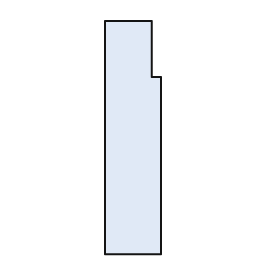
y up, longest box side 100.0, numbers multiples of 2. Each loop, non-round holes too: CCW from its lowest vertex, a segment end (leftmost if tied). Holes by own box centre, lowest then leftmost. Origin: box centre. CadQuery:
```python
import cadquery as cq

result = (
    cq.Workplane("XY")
    .moveTo(-12.0, -50.0)
    .lineTo(12.0, -50.0)
    .lineTo(12.0, 26.0)
    .lineTo(8.0, 26.0)
    .lineTo(8.0, 50.0)
    .lineTo(-12.0, 50.0)
    .close()
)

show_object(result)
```